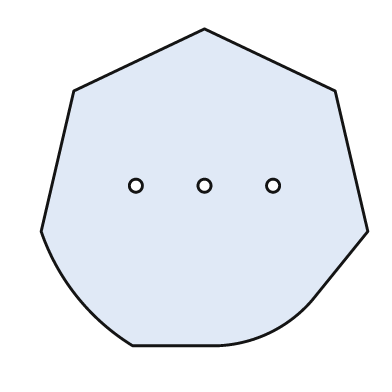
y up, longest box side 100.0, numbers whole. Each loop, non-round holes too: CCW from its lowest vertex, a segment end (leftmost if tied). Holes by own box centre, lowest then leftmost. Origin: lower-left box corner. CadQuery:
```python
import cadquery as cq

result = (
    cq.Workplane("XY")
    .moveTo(28.0, 0.0)
    .lineTo(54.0, 0.0)
    .threePointArc((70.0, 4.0), (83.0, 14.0))
    .lineTo(100.0, 35.0)
    .lineTo(90.0, 78.0)
    .lineTo(50.0, 97.0)
    .lineTo(10.0, 78.0)
    .lineTo(0.0, 35.0)
    .threePointArc((11.0, 15.0), (28.0, 0.0))
    .close()
    .moveTo(29.0, 49.0)
    .circle(2.0)
    .moveTo(50.0, 49.0)
    .circle(2.0)
    .moveTo(71.0, 49.0)
    .circle(2.0)
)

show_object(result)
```